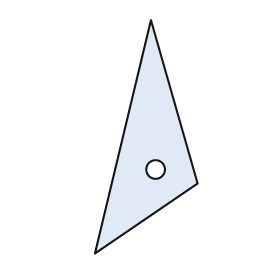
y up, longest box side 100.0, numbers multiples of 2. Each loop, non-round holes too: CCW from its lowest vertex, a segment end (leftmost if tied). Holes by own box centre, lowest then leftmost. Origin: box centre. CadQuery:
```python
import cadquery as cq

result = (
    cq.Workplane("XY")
    .moveTo(-22.0, -50.0)
    .lineTo(22.0, -20.0)
    .lineTo(2.0, 50.0)
    .close()
    .moveTo(4.0, -14.0)
    .circle(4.0)
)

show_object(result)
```